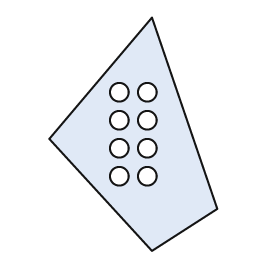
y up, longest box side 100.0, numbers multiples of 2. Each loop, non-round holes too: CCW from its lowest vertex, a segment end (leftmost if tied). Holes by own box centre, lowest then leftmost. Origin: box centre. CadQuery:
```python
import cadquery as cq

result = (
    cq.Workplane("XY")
    .moveTo(8.0, -50.0)
    .lineTo(36.0, -32.0)
    .lineTo(8.0, 50.0)
    .lineTo(-36.0, -2.0)
    .close()
    .moveTo(-6.0, -18.0)
    .circle(4.0)
    .moveTo(6.0, -18.0)
    .circle(4.0)
    .moveTo(-6.0, -6.0)
    .circle(4.0)
    .moveTo(6.0, -6.0)
    .circle(4.0)
    .moveTo(-6.0, 6.0)
    .circle(4.0)
    .moveTo(6.0, 6.0)
    .circle(4.0)
    .moveTo(-6.0, 18.0)
    .circle(4.0)
    .moveTo(6.0, 18.0)
    .circle(4.0)
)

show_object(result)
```